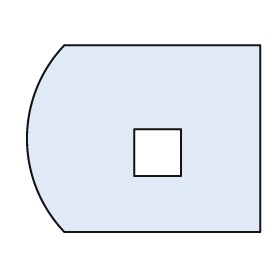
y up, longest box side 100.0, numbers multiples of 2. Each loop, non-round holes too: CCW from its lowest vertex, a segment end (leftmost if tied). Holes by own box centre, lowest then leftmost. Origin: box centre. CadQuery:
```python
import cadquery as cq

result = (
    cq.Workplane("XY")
    .moveTo(-34.0, -40.0)
    .lineTo(50.0, -40.0)
    .lineTo(50.0, 40.0)
    .lineTo(-34.0, 40.0)
    .threePointArc((-50.0, 0.0), (-34.0, -40.0))
    .close()
    .moveTo(-4.0, -16.0)
    .lineTo(16.0, -16.0)
    .lineTo(16.0, 4.0)
    .lineTo(-4.0, 4.0)
    .close()
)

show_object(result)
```